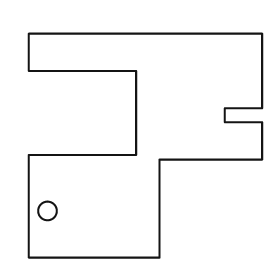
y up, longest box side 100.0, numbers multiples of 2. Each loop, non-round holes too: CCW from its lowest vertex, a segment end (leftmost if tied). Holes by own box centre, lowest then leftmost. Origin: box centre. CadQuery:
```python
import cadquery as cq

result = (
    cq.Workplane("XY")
    .moveTo(-50.0, -48.0)
    .lineTo(6.0, -48.0)
    .lineTo(6.0, -6.0)
    .lineTo(50.0, -6.0)
    .lineTo(50.0, 10.0)
    .lineTo(34.0, 10.0)
    .lineTo(34.0, 16.0)
    .lineTo(50.0, 16.0)
    .lineTo(50.0, 48.0)
    .lineTo(-50.0, 48.0)
    .lineTo(-50.0, 32.0)
    .lineTo(-4.0, 32.0)
    .lineTo(-4.0, -4.0)
    .lineTo(-50.0, -4.0)
    .close()
    .moveTo(-42.0, -28.0)
    .circle(4.0)
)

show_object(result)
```